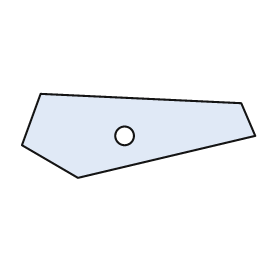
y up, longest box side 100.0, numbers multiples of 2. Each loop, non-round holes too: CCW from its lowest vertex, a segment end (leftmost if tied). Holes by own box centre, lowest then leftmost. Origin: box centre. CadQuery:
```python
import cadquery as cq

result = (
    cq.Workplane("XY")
    .moveTo(-26.0, -18.0)
    .lineTo(50.0, 0.0)
    .lineTo(44.0, 14.0)
    .lineTo(-42.0, 18.0)
    .lineTo(-50.0, -4.0)
    .close()
    .moveTo(-6.0, 0.0)
    .circle(4.0)
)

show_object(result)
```